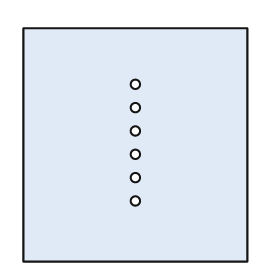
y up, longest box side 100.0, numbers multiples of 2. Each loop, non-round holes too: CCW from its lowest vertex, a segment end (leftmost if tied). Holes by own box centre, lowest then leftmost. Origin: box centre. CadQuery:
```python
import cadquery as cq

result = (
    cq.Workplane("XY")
    .moveTo(-48.0, -50.0)
    .lineTo(48.0, -50.0)
    .lineTo(48.0, 50.0)
    .lineTo(-48.0, 50.0)
    .close()
    .moveTo(0.0, -24.0)
    .circle(2.0)
    .moveTo(0.0, -14.0)
    .circle(2.0)
    .moveTo(0.0, -4.0)
    .circle(2.0)
    .moveTo(0.0, 6.0)
    .circle(2.0)
    .moveTo(0.0, 16.0)
    .circle(2.0)
    .moveTo(0.0, 26.0)
    .circle(2.0)
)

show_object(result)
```